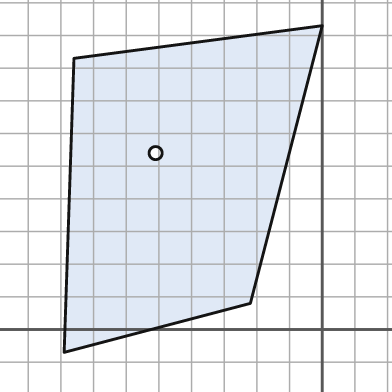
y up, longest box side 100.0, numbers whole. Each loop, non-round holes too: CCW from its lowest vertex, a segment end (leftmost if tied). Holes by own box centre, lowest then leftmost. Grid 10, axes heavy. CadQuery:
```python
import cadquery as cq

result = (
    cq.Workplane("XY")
    .moveTo(-79.0, -7.0)
    .lineTo(-22.0, 8.0)
    .lineTo(0.0, 93.0)
    .lineTo(-76.0, 83.0)
    .close()
    .moveTo(-51.0, 54.0)
    .circle(2.0)
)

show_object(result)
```